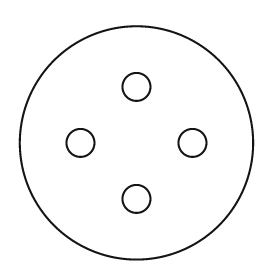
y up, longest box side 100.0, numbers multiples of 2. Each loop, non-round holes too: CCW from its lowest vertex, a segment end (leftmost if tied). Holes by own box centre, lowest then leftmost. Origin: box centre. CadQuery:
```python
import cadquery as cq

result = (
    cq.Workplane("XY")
    .moveTo(0.0, 0.0)
    .circle(50.0)
    .moveTo(0.0, -24.0)
    .circle(6.0)
    .moveTo(-24.0, 0.0)
    .circle(6.0)
    .moveTo(24.0, 0.0)
    .circle(6.0)
    .moveTo(0.0, 24.0)
    .circle(6.0)
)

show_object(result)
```